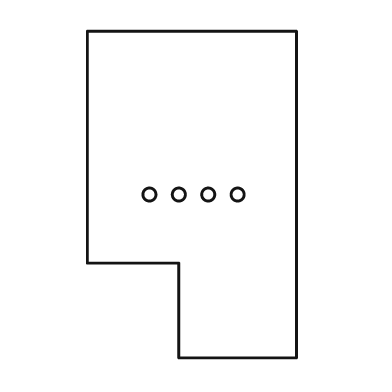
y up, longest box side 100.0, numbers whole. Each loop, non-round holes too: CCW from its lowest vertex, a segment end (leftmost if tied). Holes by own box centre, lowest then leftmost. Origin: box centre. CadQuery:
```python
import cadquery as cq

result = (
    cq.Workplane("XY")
    .moveTo(-4.0, -50.0)
    .lineTo(32.0, -50.0)
    .lineTo(32.0, 50.0)
    .lineTo(-32.0, 50.0)
    .lineTo(-32.0, -21.0)
    .lineTo(-4.0, -21.0)
    .close()
    .moveTo(-13.0, 0.0)
    .circle(2.0)
    .moveTo(-4.0, 0.0)
    .circle(2.0)
    .moveTo(5.0, 0.0)
    .circle(2.0)
    .moveTo(14.0, 0.0)
    .circle(2.0)
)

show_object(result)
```